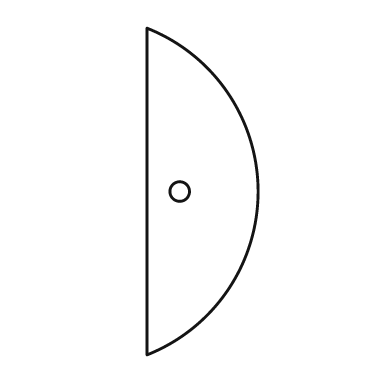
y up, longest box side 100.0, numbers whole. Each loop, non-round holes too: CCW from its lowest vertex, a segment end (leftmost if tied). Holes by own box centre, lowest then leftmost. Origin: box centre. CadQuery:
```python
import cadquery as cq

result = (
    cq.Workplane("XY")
    .moveTo(-17.0, -50.0)
    .threePointArc((17.0, 0.0), (-17.0, 50.0))
    .close()
    .moveTo(-7.0, 0.0)
    .circle(3.0)
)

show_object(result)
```